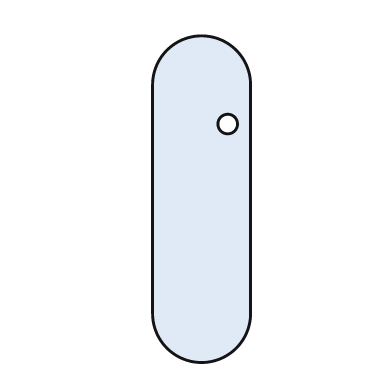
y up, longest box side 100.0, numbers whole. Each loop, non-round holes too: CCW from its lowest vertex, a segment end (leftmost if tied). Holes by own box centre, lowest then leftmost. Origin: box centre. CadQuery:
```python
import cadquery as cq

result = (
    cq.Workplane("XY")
    .moveTo(-15.0, -35.0)
    .threePointArc((0.0, -50.0), (15.0, -35.0))
    .lineTo(15.0, 35.0)
    .threePointArc((0.0, 50.0), (-15.0, 35.0))
    .close()
    .moveTo(8.0, 23.0)
    .circle(3.0)
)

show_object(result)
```